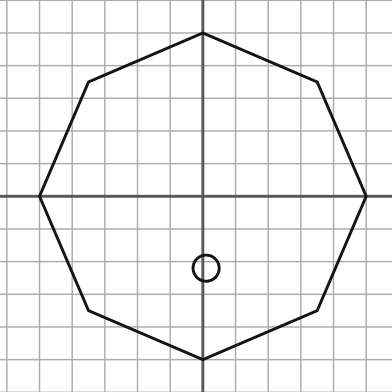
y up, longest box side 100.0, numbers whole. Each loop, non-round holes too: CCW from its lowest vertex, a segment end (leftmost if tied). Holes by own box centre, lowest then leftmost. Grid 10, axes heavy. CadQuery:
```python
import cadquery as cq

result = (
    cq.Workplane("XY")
    .moveTo(0.0, -50.0)
    .lineTo(35.0, -35.0)
    .lineTo(50.0, 0.0)
    .lineTo(35.0, 35.0)
    .lineTo(0.0, 50.0)
    .lineTo(-35.0, 35.0)
    .lineTo(-50.0, 0.0)
    .lineTo(-35.0, -35.0)
    .close()
    .moveTo(1.0, -22.0)
    .circle(4.0)
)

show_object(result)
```